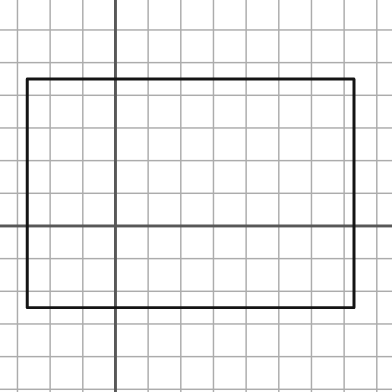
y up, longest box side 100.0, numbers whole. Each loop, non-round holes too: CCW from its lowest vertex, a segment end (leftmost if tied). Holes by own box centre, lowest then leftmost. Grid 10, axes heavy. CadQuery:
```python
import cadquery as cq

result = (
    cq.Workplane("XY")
    .moveTo(-27.0, -25.0)
    .lineTo(73.0, -25.0)
    .lineTo(73.0, 45.0)
    .lineTo(-27.0, 45.0)
    .close()
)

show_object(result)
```